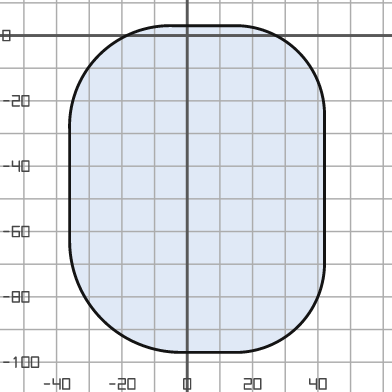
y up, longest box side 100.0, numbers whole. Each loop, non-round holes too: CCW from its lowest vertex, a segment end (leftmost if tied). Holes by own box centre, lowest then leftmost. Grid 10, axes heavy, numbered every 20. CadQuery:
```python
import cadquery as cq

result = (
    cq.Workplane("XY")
    .moveTo(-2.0, -97.0)
    .lineTo(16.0, -97.0)
    .threePointArc((34.0, -89.0), (42.0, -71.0))
    .lineTo(42.0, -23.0)
    .threePointArc((34.0, -5.0), (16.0, 3.0))
    .lineTo(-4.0, 3.0)
    .threePointArc((-27.0, -6.0), (-36.0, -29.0))
    .lineTo(-36.0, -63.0)
    .threePointArc((-26.0, -87.0), (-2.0, -97.0))
    .close()
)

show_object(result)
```